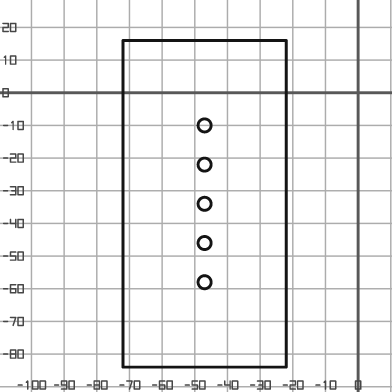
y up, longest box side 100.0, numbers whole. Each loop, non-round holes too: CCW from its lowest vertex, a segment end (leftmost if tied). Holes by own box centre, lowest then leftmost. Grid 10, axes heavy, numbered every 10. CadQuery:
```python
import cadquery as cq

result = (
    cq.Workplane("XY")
    .moveTo(-72.0, -84.0)
    .lineTo(-22.0, -84.0)
    .lineTo(-22.0, 16.0)
    .lineTo(-72.0, 16.0)
    .close()
    .moveTo(-47.0, -58.0)
    .circle(2.0)
    .moveTo(-47.0, -46.0)
    .circle(2.0)
    .moveTo(-47.0, -34.0)
    .circle(2.0)
    .moveTo(-47.0, -22.0)
    .circle(2.0)
    .moveTo(-47.0, -10.0)
    .circle(2.0)
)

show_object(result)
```